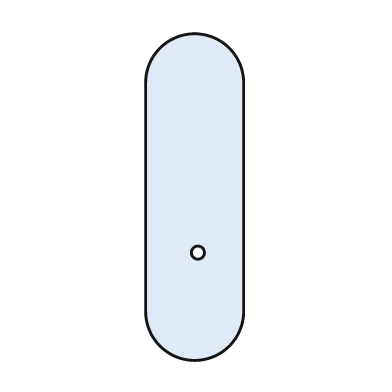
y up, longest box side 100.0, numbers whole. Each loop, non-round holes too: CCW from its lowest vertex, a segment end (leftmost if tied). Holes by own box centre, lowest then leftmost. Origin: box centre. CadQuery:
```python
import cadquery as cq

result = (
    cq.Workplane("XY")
    .moveTo(-15.0, -35.0)
    .threePointArc((0.0, -50.0), (15.0, -35.0))
    .lineTo(15.0, 35.0)
    .threePointArc((0.0, 50.0), (-15.0, 35.0))
    .close()
    .moveTo(1.0, -17.0)
    .circle(2.0)
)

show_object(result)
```